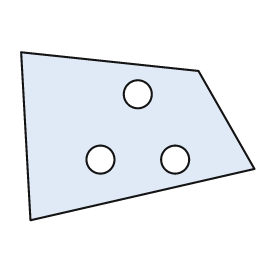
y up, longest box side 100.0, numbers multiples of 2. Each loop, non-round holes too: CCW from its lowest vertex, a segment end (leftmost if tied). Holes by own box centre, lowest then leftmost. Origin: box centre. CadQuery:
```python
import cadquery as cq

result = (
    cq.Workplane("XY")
    .moveTo(-46.0, -36.0)
    .lineTo(50.0, -14.0)
    .lineTo(26.0, 28.0)
    .lineTo(-50.0, 36.0)
    .close()
    .moveTo(-16.0, -10.0)
    .circle(6.0)
    .moveTo(16.0, -10.0)
    .circle(6.0)
    .moveTo(0.0, 18.0)
    .circle(6.0)
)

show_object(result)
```